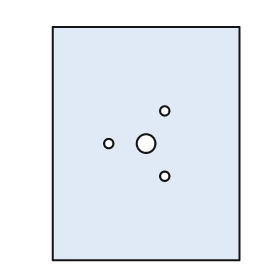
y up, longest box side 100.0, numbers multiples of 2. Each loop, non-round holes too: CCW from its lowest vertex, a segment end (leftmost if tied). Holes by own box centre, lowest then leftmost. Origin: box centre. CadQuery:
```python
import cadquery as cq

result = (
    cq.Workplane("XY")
    .moveTo(-40.0, -50.0)
    .lineTo(40.0, -50.0)
    .lineTo(40.0, 50.0)
    .lineTo(-40.0, 50.0)
    .close()
    .moveTo(8.0, -14.0)
    .circle(2.0)
    .moveTo(-16.0, 0.0)
    .circle(2.0)
    .moveTo(0.0, 0.0)
    .circle(4.0)
    .moveTo(8.0, 14.0)
    .circle(2.0)
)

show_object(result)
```